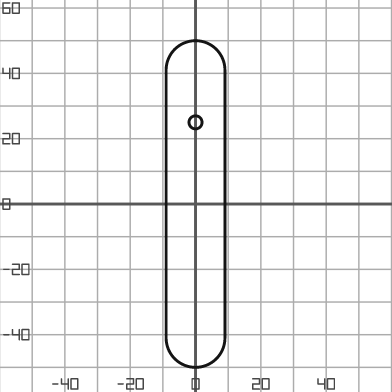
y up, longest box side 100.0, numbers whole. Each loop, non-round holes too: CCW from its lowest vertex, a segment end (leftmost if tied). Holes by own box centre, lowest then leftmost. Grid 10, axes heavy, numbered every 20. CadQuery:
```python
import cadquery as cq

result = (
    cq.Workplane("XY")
    .moveTo(-9.0, -41.0)
    .threePointArc((0.0, -50.0), (9.0, -41.0))
    .lineTo(9.0, 41.0)
    .threePointArc((0.0, 50.0), (-9.0, 41.0))
    .close()
    .moveTo(0.0, 25.0)
    .circle(2.0)
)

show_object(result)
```